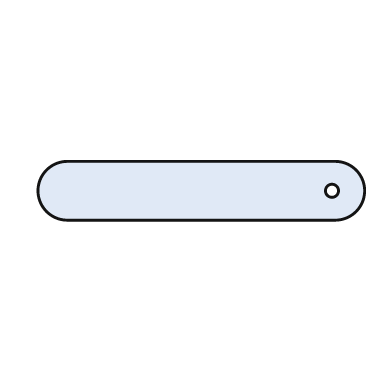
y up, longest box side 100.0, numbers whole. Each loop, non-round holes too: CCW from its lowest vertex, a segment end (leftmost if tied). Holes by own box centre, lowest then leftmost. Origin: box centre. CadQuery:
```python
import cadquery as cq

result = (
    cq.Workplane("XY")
    .moveTo(-41.0, -9.0)
    .lineTo(41.0, -9.0)
    .threePointArc((50.0, 0.0), (41.0, 9.0))
    .lineTo(-41.0, 9.0)
    .threePointArc((-50.0, 0.0), (-41.0, -9.0))
    .close()
    .moveTo(40.0, 0.0)
    .circle(2.0)
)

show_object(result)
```